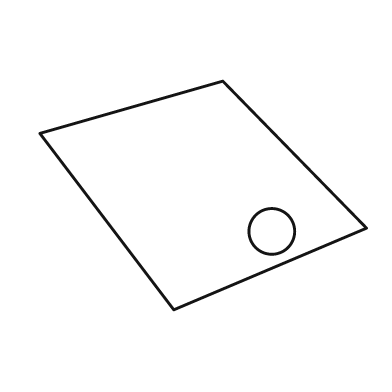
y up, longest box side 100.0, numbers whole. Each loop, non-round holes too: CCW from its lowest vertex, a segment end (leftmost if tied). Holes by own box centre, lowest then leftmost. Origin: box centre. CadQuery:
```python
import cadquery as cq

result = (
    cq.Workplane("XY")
    .moveTo(-9.0, -35.0)
    .lineTo(50.0, -10.0)
    .lineTo(6.0, 35.0)
    .lineTo(-50.0, 19.0)
    .close()
    .moveTo(21.0, -11.0)
    .circle(7.0)
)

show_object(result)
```